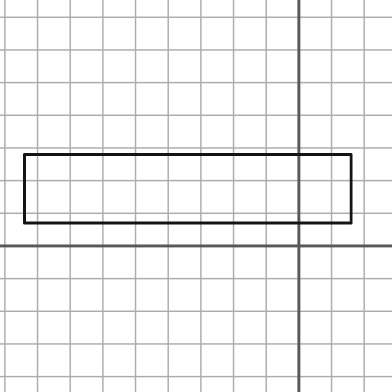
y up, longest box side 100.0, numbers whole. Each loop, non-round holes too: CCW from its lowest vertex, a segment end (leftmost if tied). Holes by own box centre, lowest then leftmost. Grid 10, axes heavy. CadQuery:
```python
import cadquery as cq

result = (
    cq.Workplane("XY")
    .moveTo(-84.0, 7.0)
    .lineTo(16.0, 7.0)
    .lineTo(16.0, 28.0)
    .lineTo(-84.0, 28.0)
    .close()
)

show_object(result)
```